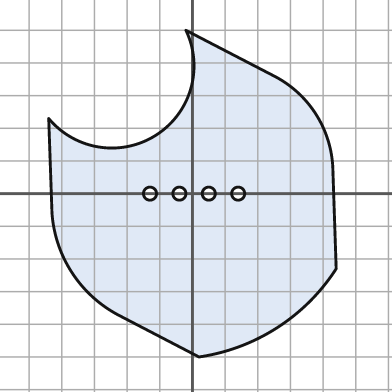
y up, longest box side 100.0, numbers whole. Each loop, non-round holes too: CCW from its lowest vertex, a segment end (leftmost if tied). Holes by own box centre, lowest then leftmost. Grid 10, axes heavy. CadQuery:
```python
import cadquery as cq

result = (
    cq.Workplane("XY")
    .moveTo(2.0, -50.0)
    .threePointArc((26.0, -41.0), (44.0, -23.0))
    .lineTo(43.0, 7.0)
    .threePointArc((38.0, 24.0), (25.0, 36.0))
    .lineTo(-2.0, 50.0)
    .threePointArc((-11.0, 18.0), (-44.0, 23.0))
    .lineTo(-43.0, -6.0)
    .threePointArc((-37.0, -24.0), (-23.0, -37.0))
    .close()
    .moveTo(-13.0, 0.0)
    .circle(2.0)
    .moveTo(-4.0, 0.0)
    .circle(2.0)
    .moveTo(5.0, 0.0)
    .circle(2.0)
    .moveTo(14.0, 0.0)
    .circle(2.0)
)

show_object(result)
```